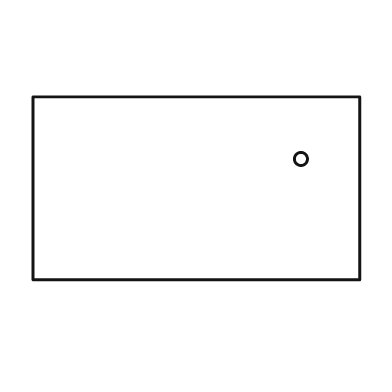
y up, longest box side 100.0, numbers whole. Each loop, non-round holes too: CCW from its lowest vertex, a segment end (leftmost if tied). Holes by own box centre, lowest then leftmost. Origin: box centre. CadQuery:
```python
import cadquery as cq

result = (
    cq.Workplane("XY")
    .moveTo(-50.0, -28.0)
    .lineTo(50.0, -28.0)
    .lineTo(50.0, 28.0)
    .lineTo(-50.0, 28.0)
    .close()
    .moveTo(32.0, 9.0)
    .circle(2.0)
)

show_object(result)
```